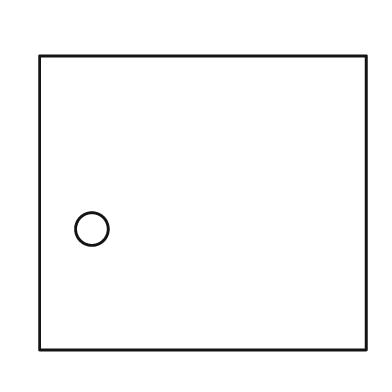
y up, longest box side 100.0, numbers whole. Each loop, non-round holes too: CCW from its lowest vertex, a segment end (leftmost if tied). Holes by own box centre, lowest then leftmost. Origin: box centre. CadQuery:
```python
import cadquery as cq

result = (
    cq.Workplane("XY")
    .moveTo(-50.0, -45.0)
    .lineTo(50.0, -45.0)
    .lineTo(50.0, 45.0)
    .lineTo(-50.0, 45.0)
    .close()
    .moveTo(-34.0, -8.0)
    .circle(5.0)
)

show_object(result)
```